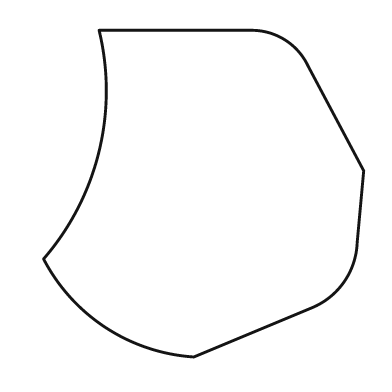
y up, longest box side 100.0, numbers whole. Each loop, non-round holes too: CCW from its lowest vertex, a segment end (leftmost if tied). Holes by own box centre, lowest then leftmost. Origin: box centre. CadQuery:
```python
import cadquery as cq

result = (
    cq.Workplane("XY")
    .moveTo(-3.0, -50.0)
    .lineTo(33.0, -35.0)
    .threePointArc((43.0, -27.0), (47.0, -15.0))
    .lineTo(49.0, 7.0)
    .lineTo(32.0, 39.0)
    .threePointArc((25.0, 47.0), (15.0, 50.0))
    .lineTo(-32.0, 50.0)
    .threePointArc((-32.0, 13.0), (-49.0, -20.0))
    .threePointArc((-30.0, -41.0), (-3.0, -50.0))
    .close()
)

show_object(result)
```